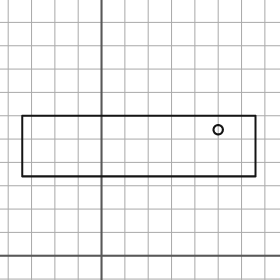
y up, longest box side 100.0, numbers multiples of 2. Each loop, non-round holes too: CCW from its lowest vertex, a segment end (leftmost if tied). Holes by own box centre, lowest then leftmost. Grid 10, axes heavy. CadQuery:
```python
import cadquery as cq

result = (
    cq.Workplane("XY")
    .moveTo(-34.0, 34.0)
    .lineTo(66.0, 34.0)
    .lineTo(66.0, 60.0)
    .lineTo(-34.0, 60.0)
    .close()
    .moveTo(50.0, 54.0)
    .circle(2.0)
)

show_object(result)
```